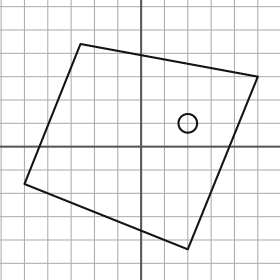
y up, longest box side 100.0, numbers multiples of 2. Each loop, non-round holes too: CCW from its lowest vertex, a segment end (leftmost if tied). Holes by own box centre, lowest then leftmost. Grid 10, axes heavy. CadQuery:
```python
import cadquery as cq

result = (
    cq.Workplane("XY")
    .moveTo(20.0, -44.0)
    .lineTo(50.0, 30.0)
    .lineTo(-26.0, 44.0)
    .lineTo(-50.0, -16.0)
    .close()
    .moveTo(20.0, 10.0)
    .circle(4.0)
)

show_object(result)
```